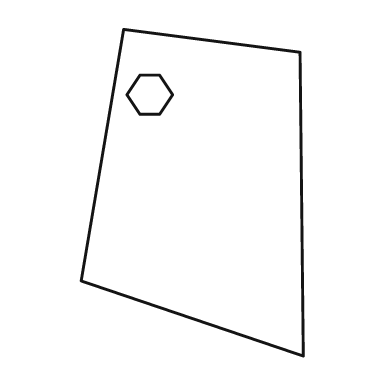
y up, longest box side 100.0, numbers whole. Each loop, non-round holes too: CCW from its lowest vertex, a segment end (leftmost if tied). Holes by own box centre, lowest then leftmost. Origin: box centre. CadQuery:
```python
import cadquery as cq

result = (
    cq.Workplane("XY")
    .moveTo(34.0, -50.0)
    .lineTo(33.0, 43.0)
    .lineTo(-21.0, 50.0)
    .lineTo(-34.0, -27.0)
    .close()
    .moveTo(-16.0, 24.0)
    .lineTo(-10.0, 24.0)
    .lineTo(-6.0, 30.0)
    .lineTo(-10.0, 36.0)
    .lineTo(-16.0, 36.0)
    .lineTo(-20.0, 30.0)
    .close()
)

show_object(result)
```